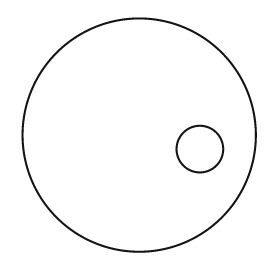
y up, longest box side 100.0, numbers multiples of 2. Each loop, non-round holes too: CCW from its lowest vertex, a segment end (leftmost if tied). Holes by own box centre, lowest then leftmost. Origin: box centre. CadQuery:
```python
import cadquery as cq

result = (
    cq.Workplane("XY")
    .moveTo(0.0, 0.0)
    .circle(50.0)
    .moveTo(26.0, -6.0)
    .circle(10.0)
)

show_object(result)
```